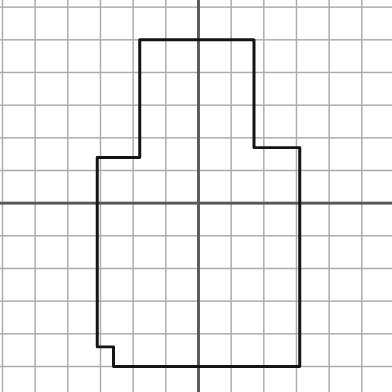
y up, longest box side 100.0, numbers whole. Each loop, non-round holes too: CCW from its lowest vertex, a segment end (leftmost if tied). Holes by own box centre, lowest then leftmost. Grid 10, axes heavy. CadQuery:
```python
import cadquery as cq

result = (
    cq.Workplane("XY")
    .moveTo(-26.0, -50.0)
    .lineTo(31.0, -50.0)
    .lineTo(31.0, 17.0)
    .lineTo(17.0, 17.0)
    .lineTo(17.0, 50.0)
    .lineTo(-18.0, 50.0)
    .lineTo(-18.0, 14.0)
    .lineTo(-31.0, 14.0)
    .lineTo(-31.0, -44.0)
    .lineTo(-26.0, -44.0)
    .close()
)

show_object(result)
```